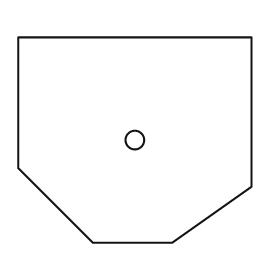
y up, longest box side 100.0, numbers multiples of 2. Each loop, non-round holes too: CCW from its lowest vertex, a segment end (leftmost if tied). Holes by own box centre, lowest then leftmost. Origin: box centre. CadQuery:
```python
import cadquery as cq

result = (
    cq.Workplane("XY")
    .moveTo(-18.0, -44.0)
    .lineTo(16.0, -44.0)
    .lineTo(50.0, -20.0)
    .lineTo(50.0, 44.0)
    .lineTo(-50.0, 44.0)
    .lineTo(-50.0, -12.0)
    .close()
    .moveTo(0.0, 0.0)
    .circle(4.0)
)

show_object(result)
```